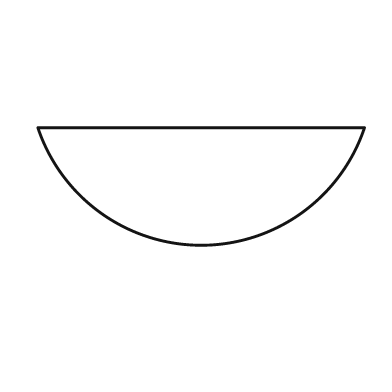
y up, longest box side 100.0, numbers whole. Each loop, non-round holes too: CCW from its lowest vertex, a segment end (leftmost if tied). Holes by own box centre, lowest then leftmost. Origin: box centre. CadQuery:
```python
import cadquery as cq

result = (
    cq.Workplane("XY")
    .moveTo(-50.0, 18.0)
    .threePointArc((0.0, -18.0), (50.0, 18.0))
    .close()
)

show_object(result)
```